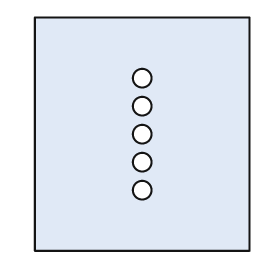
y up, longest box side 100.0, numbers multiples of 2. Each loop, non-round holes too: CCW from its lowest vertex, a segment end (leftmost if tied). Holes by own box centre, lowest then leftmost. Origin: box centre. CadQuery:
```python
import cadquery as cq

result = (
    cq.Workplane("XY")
    .moveTo(-46.0, -50.0)
    .lineTo(46.0, -50.0)
    .lineTo(46.0, 50.0)
    .lineTo(-46.0, 50.0)
    .close()
    .moveTo(0.0, -24.0)
    .circle(4.0)
    .moveTo(0.0, -12.0)
    .circle(4.0)
    .moveTo(0.0, 0.0)
    .circle(4.0)
    .moveTo(0.0, 12.0)
    .circle(4.0)
    .moveTo(0.0, 24.0)
    .circle(4.0)
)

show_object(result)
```